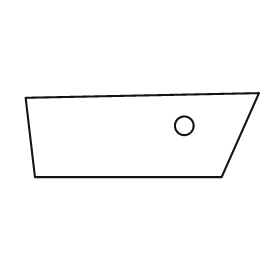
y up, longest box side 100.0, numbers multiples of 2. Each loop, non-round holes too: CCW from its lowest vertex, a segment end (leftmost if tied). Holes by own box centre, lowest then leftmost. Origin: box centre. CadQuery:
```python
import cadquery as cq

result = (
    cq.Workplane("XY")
    .moveTo(-46.0, -18.0)
    .lineTo(34.0, -18.0)
    .lineTo(50.0, 18.0)
    .lineTo(-50.0, 16.0)
    .close()
    .moveTo(18.0, 4.0)
    .circle(4.0)
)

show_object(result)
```